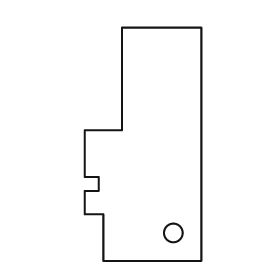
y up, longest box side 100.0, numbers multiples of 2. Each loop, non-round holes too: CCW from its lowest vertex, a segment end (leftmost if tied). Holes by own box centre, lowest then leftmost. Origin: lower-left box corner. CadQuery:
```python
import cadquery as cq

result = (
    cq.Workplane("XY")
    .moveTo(8.0, 0.0)
    .lineTo(50.0, 0.0)
    .lineTo(50.0, 100.0)
    .lineTo(16.0, 100.0)
    .lineTo(16.0, 56.0)
    .lineTo(0.0, 56.0)
    .lineTo(0.0, 36.0)
    .lineTo(6.0, 36.0)
    .lineTo(6.0, 30.0)
    .lineTo(0.0, 30.0)
    .lineTo(0.0, 20.0)
    .lineTo(8.0, 20.0)
    .close()
    .moveTo(38.0, 12.0)
    .circle(4.0)
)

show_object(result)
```